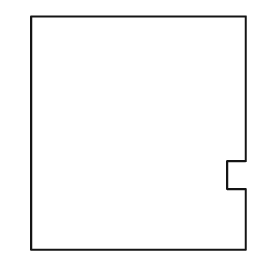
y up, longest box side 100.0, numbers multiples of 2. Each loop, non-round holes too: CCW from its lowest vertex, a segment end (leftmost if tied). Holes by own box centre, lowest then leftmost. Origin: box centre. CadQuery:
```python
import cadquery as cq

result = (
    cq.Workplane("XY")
    .moveTo(-46.0, -50.0)
    .lineTo(46.0, -50.0)
    .lineTo(46.0, -24.0)
    .lineTo(38.0, -24.0)
    .lineTo(38.0, -12.0)
    .lineTo(46.0, -12.0)
    .lineTo(46.0, 50.0)
    .lineTo(-46.0, 50.0)
    .close()
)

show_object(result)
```